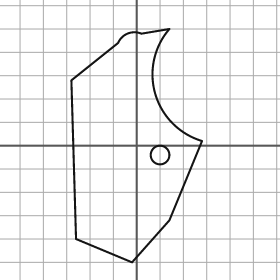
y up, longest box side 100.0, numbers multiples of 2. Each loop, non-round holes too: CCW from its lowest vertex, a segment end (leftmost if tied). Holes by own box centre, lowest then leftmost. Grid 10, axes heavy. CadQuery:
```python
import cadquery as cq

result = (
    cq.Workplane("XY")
    .moveTo(-2.0, -50.0)
    .lineTo(14.0, -32.0)
    .lineTo(28.0, 2.0)
    .threePointArc((8.0, 22.0), (14.0, 50.0))
    .lineTo(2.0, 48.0)
    .threePointArc((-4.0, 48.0), (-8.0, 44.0))
    .lineTo(-28.0, 28.0)
    .lineTo(-26.0, -40.0)
    .close()
    .moveTo(10.0, -4.0)
    .circle(4.0)
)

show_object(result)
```